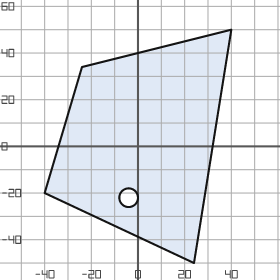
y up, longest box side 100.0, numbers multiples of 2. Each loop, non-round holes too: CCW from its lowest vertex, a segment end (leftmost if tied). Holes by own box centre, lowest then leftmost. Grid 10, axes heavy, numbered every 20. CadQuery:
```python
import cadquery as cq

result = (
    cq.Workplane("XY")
    .moveTo(24.0, -50.0)
    .lineTo(40.0, 50.0)
    .lineTo(-24.0, 34.0)
    .lineTo(-40.0, -20.0)
    .close()
    .moveTo(-4.0, -22.0)
    .circle(4.0)
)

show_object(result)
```